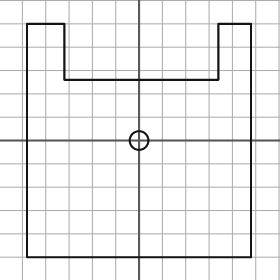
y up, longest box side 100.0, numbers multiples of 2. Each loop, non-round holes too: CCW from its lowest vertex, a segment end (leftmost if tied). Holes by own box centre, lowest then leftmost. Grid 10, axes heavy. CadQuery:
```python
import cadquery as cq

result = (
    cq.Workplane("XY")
    .moveTo(-48.0, -50.0)
    .lineTo(48.0, -50.0)
    .lineTo(48.0, 50.0)
    .lineTo(34.0, 50.0)
    .lineTo(34.0, 26.0)
    .lineTo(-32.0, 26.0)
    .lineTo(-32.0, 50.0)
    .lineTo(-48.0, 50.0)
    .close()
    .moveTo(0.0, 0.0)
    .circle(4.0)
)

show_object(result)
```